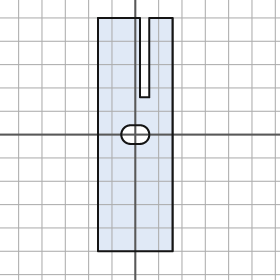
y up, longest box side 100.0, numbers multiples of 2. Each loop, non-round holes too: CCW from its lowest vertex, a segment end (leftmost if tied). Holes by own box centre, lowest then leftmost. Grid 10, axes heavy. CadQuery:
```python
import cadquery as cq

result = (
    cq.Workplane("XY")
    .moveTo(-16.0, -50.0)
    .lineTo(16.0, -50.0)
    .lineTo(16.0, 50.0)
    .lineTo(6.0, 50.0)
    .lineTo(6.0, 16.0)
    .lineTo(2.0, 16.0)
    .lineTo(2.0, 50.0)
    .lineTo(-16.0, 50.0)
    .close()
    .moveTo(-2.0, -4.0)
    .lineTo(2.0, -4.0)
    .threePointArc((6.0, 0.0), (2.0, 4.0))
    .lineTo(-2.0, 4.0)
    .threePointArc((-6.0, 0.0), (-2.0, -4.0))
    .close()
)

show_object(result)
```